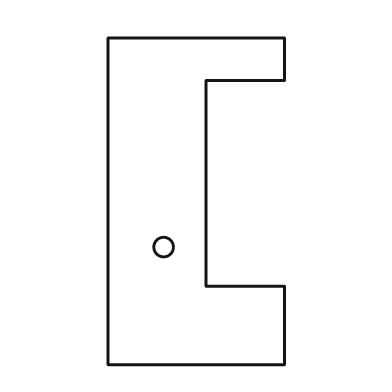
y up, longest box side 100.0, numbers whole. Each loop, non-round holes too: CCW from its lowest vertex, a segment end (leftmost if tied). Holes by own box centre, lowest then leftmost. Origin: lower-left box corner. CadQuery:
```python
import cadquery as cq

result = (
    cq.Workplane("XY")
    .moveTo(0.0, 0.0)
    .lineTo(54.0, 0.0)
    .lineTo(54.0, 24.0)
    .lineTo(30.0, 24.0)
    .lineTo(30.0, 87.0)
    .lineTo(54.0, 87.0)
    .lineTo(54.0, 100.0)
    .lineTo(0.0, 100.0)
    .close()
    .moveTo(17.0, 36.0)
    .circle(3.0)
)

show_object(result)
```